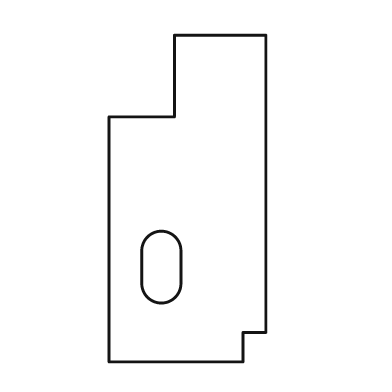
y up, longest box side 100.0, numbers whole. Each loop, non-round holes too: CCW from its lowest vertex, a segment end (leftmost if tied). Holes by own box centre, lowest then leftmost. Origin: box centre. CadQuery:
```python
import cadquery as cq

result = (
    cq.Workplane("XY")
    .moveTo(-24.0, -50.0)
    .lineTo(17.0, -50.0)
    .lineTo(17.0, -41.0)
    .lineTo(24.0, -41.0)
    .lineTo(24.0, 50.0)
    .lineTo(-4.0, 50.0)
    .lineTo(-4.0, 25.0)
    .lineTo(-24.0, 25.0)
    .close()
    .moveTo(-14.0, -26.0)
    .threePointArc((-8.0, -32.0), (-2.0, -26.0))
    .lineTo(-2.0, -16.0)
    .threePointArc((-8.0, -10.0), (-14.0, -16.0))
    .close()
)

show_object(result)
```